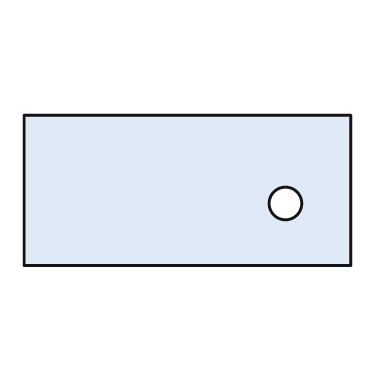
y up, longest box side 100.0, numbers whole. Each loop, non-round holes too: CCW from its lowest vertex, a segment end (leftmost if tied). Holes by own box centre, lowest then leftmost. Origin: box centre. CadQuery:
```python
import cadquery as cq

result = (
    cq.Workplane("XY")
    .moveTo(-50.0, -23.0)
    .lineTo(50.0, -23.0)
    .lineTo(50.0, 23.0)
    .lineTo(-50.0, 23.0)
    .close()
    .moveTo(30.0, -4.0)
    .circle(5.0)
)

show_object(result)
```